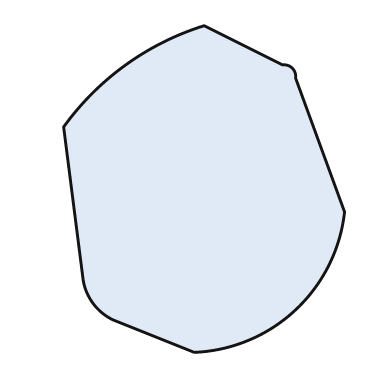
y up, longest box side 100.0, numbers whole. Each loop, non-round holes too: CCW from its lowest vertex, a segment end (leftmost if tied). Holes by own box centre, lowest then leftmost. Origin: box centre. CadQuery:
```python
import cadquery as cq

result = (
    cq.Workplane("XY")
    .moveTo(-3.0, -50.0)
    .threePointArc((28.0, -37.0), (43.0, -7.0))
    .lineTo(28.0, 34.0)
    .threePointArc((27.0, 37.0), (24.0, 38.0))
    .lineTo(0.0, 50.0)
    .threePointArc((-24.0, 38.0), (-43.0, 19.0))
    .lineTo(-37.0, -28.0)
    .threePointArc((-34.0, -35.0), (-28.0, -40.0))
    .close()
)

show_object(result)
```